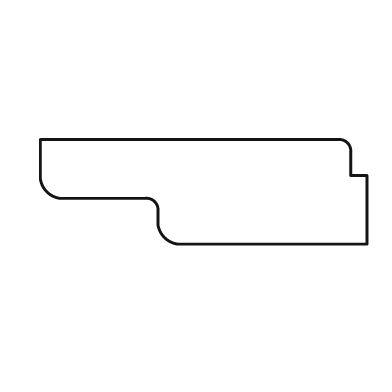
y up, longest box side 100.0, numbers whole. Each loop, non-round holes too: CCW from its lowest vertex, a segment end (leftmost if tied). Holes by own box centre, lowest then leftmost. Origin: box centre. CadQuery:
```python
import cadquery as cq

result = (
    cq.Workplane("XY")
    .moveTo(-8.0, -16.0)
    .lineTo(50.0, -16.0)
    .lineTo(50.0, 5.0)
    .lineTo(45.0, 5.0)
    .lineTo(45.0, 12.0)
    .threePointArc((44.0, 15.0), (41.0, 16.0))
    .lineTo(-50.0, 16.0)
    .lineTo(-50.0, 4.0)
    .threePointArc((-48.0, 0.0), (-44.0, -2.0))
    .lineTo(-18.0, -2.0)
    .threePointArc((-15.0, -3.0), (-14.0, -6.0))
    .lineTo(-14.0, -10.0)
    .threePointArc((-12.0, -14.0), (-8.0, -16.0))
    .close()
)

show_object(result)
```